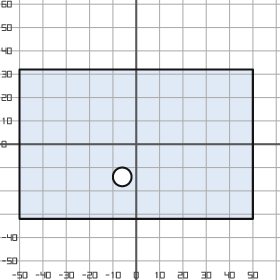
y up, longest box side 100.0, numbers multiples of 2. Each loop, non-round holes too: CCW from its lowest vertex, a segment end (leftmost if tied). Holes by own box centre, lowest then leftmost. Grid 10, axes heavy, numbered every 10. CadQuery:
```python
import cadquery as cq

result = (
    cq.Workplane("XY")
    .moveTo(-50.0, -32.0)
    .lineTo(50.0, -32.0)
    .lineTo(50.0, 32.0)
    .lineTo(-50.0, 32.0)
    .close()
    .moveTo(-6.0, -14.0)
    .circle(4.0)
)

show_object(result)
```